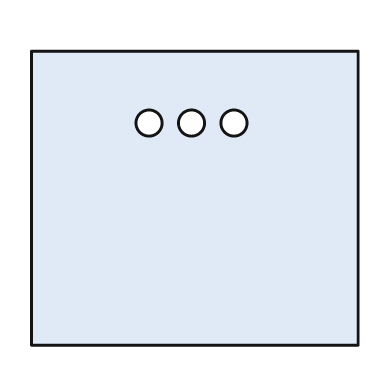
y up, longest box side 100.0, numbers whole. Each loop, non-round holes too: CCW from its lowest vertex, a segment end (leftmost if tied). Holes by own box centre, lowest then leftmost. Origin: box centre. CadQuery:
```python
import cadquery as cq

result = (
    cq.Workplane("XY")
    .moveTo(-50.0, -45.0)
    .lineTo(50.0, -45.0)
    .lineTo(50.0, 45.0)
    .lineTo(-50.0, 45.0)
    .close()
    .moveTo(-14.0, 23.0)
    .circle(4.0)
    .moveTo(-1.0, 23.0)
    .circle(4.0)
    .moveTo(12.0, 23.0)
    .circle(4.0)
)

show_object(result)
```